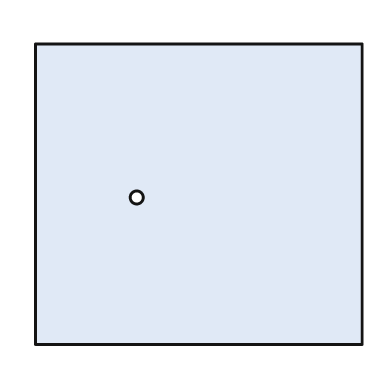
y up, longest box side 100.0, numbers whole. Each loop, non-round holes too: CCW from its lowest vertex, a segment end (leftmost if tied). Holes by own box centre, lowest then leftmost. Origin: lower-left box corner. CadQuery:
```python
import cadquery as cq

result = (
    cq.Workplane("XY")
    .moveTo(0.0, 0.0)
    .lineTo(100.0, 0.0)
    .lineTo(100.0, 92.0)
    .lineTo(0.0, 92.0)
    .close()
    .moveTo(31.0, 45.0)
    .circle(2.0)
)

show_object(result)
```